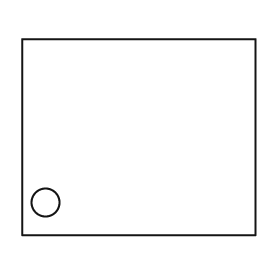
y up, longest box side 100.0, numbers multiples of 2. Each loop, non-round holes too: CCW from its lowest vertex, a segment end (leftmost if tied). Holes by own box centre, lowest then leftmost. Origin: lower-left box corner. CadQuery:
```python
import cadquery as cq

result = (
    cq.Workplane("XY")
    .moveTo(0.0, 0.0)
    .lineTo(100.0, 0.0)
    .lineTo(100.0, 84.0)
    .lineTo(0.0, 84.0)
    .close()
    .moveTo(10.0, 14.0)
    .circle(6.0)
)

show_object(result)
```